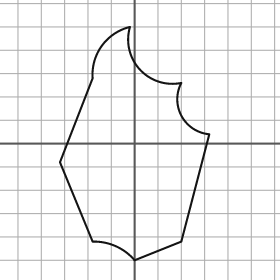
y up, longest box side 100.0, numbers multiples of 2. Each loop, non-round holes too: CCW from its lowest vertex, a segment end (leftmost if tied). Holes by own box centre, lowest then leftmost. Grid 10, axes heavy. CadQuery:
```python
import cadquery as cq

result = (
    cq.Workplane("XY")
    .moveTo(0.0, -50.0)
    .lineTo(20.0, -42.0)
    .lineTo(32.0, 4.0)
    .threePointArc((20.0, 12.0), (20.0, 26.0))
    .threePointArc((2.0, 32.0), (-2.0, 50.0))
    .threePointArc((-14.0, 42.0), (-18.0, 28.0))
    .lineTo(-32.0, -8.0)
    .lineTo(-18.0, -42.0)
    .threePointArc((-8.0, -44.0), (0.0, -50.0))
    .close()
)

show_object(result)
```